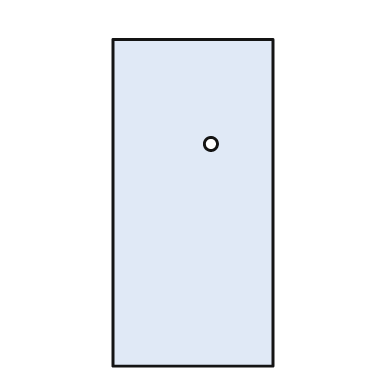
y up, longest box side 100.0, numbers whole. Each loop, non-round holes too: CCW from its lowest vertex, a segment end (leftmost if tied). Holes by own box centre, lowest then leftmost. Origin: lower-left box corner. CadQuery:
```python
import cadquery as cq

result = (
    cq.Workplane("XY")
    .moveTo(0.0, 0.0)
    .lineTo(49.0, 0.0)
    .lineTo(49.0, 100.0)
    .lineTo(0.0, 100.0)
    .close()
    .moveTo(30.0, 68.0)
    .circle(2.0)
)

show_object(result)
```